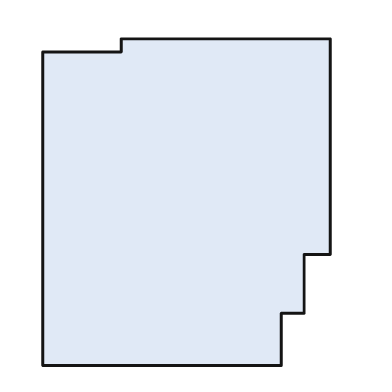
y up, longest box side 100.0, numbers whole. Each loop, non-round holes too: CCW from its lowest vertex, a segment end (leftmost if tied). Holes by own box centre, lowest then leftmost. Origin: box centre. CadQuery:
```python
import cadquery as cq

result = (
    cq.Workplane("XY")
    .moveTo(-44.0, -50.0)
    .lineTo(29.0, -50.0)
    .lineTo(29.0, -34.0)
    .lineTo(36.0, -34.0)
    .lineTo(36.0, -16.0)
    .lineTo(44.0, -16.0)
    .lineTo(44.0, 50.0)
    .lineTo(-20.0, 50.0)
    .lineTo(-20.0, 46.0)
    .lineTo(-44.0, 46.0)
    .close()
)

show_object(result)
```